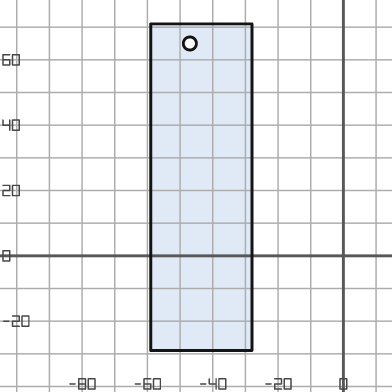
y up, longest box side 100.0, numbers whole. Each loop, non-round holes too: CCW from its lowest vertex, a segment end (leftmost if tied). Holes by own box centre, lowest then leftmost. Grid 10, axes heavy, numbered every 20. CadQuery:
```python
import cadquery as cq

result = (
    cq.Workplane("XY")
    .moveTo(-59.0, -29.0)
    .lineTo(-28.0, -29.0)
    .lineTo(-28.0, 71.0)
    .lineTo(-59.0, 71.0)
    .close()
    .moveTo(-47.0, 65.0)
    .circle(2.0)
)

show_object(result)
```